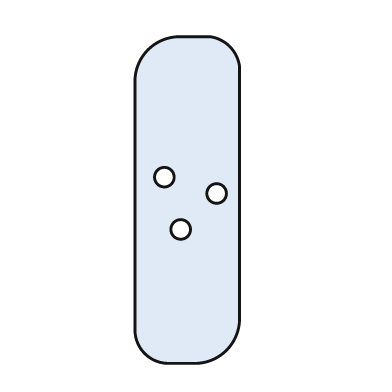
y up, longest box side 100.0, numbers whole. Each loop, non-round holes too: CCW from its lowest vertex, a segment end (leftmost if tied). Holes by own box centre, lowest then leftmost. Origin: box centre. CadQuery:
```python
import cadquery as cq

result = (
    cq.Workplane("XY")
    .moveTo(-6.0, -50.0)
    .lineTo(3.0, -50.0)
    .threePointArc((12.0, -46.0), (16.0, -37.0))
    .lineTo(16.0, 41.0)
    .threePointArc((13.0, 47.0), (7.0, 50.0))
    .lineTo(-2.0, 50.0)
    .threePointArc((-12.0, 46.0), (-16.0, 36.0))
    .lineTo(-16.0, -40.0)
    .threePointArc((-13.0, -47.0), (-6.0, -50.0))
    .close()
    .moveTo(-2.0, -9.0)
    .circle(3.0)
    .moveTo(9.0, 2.0)
    .circle(3.0)
    .moveTo(-7.0, 7.0)
    .circle(3.0)
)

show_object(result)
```